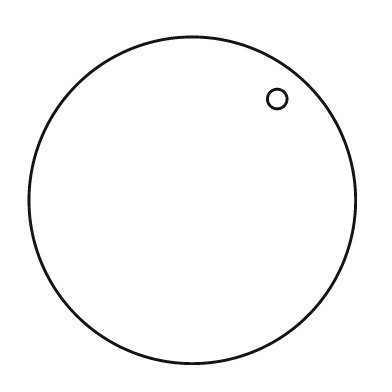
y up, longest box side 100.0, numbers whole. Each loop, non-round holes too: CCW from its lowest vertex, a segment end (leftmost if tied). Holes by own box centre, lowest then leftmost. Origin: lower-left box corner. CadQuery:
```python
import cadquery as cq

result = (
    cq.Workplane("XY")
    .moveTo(50.0, 50.0)
    .circle(50.0)
    .moveTo(76.0, 81.0)
    .circle(3.0)
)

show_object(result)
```